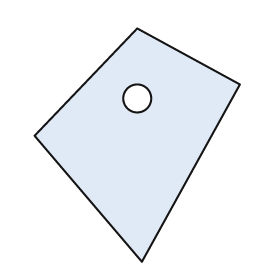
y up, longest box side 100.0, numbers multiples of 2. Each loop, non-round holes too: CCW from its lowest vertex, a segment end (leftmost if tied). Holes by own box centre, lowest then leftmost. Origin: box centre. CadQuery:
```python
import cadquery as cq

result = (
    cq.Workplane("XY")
    .moveTo(2.0, -50.0)
    .lineTo(44.0, 26.0)
    .lineTo(0.0, 50.0)
    .lineTo(-44.0, 4.0)
    .close()
    .moveTo(0.0, 20.0)
    .circle(6.0)
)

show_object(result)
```